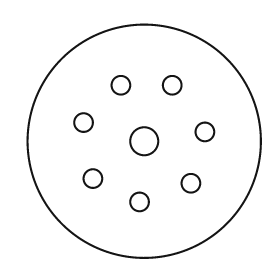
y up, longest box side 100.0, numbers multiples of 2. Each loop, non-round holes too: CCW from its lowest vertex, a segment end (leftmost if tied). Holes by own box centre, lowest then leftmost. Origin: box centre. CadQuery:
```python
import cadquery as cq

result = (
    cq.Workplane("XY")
    .moveTo(0.0, 0.0)
    .circle(50.0)
    .moveTo(-2.0, -26.0)
    .circle(4.0)
    .moveTo(20.0, -18.0)
    .circle(4.0)
    .moveTo(-22.0, -16.0)
    .circle(4.0)
    .moveTo(0.0, 0.0)
    .circle(6.0)
    .moveTo(26.0, 4.0)
    .circle(4.0)
    .moveTo(-26.0, 8.0)
    .circle(4.0)
    .moveTo(-10.0, 24.0)
    .circle(4.0)
    .moveTo(12.0, 24.0)
    .circle(4.0)
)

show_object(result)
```